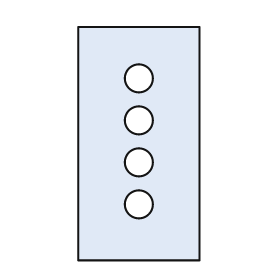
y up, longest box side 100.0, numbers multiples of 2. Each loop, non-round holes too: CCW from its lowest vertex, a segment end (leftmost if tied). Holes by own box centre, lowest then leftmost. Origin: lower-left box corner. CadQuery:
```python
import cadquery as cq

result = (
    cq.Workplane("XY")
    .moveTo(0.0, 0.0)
    .lineTo(52.0, 0.0)
    .lineTo(52.0, 100.0)
    .lineTo(0.0, 100.0)
    .close()
    .moveTo(26.0, 24.0)
    .circle(6.0)
    .moveTo(26.0, 42.0)
    .circle(6.0)
    .moveTo(26.0, 60.0)
    .circle(6.0)
    .moveTo(26.0, 78.0)
    .circle(6.0)
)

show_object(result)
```